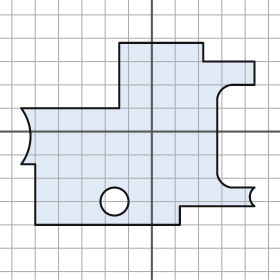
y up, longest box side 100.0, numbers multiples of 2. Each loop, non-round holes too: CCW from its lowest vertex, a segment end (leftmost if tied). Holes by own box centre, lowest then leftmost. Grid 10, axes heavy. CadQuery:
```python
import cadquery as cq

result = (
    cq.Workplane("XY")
    .moveTo(-50.0, -40.0)
    .lineTo(12.0, -40.0)
    .lineTo(12.0, -32.0)
    .lineTo(44.0, -32.0)
    .threePointArc((42.0, -28.0), (44.0, -24.0))
    .lineTo(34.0, -24.0)
    .threePointArc((30.0, -22.0), (28.0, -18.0))
    .lineTo(28.0, 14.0)
    .threePointArc((30.0, 18.0), (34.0, 20.0))
    .lineTo(44.0, 20.0)
    .lineTo(44.0, 30.0)
    .lineTo(22.0, 30.0)
    .lineTo(22.0, 38.0)
    .lineTo(-14.0, 38.0)
    .lineTo(-14.0, 10.0)
    .lineTo(-56.0, 10.0)
    .threePointArc((-52.0, -2.0), (-56.0, -14.0))
    .lineTo(-50.0, -14.0)
    .close()
    .moveTo(-16.0, -30.0)
    .circle(6.0)
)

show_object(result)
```